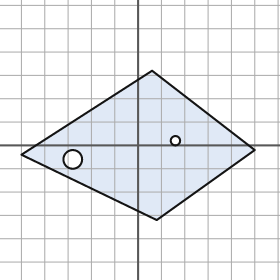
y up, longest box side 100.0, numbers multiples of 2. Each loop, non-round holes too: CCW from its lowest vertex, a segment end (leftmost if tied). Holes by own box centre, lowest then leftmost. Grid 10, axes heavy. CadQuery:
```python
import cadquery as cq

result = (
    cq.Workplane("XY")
    .moveTo(8.0, -32.0)
    .lineTo(50.0, -2.0)
    .lineTo(6.0, 32.0)
    .lineTo(-50.0, -4.0)
    .close()
    .moveTo(-28.0, -6.0)
    .circle(4.0)
    .moveTo(16.0, 2.0)
    .circle(2.0)
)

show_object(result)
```